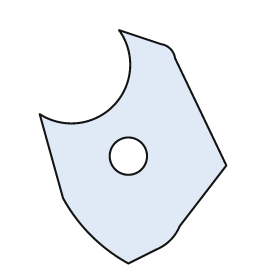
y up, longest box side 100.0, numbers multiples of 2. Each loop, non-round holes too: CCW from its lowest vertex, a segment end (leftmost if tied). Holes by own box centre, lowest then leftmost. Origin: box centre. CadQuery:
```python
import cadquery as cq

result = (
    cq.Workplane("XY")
    .moveTo(-2.0, -50.0)
    .lineTo(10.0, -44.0)
    .threePointArc((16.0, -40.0), (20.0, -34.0))
    .lineTo(40.0, -8.0)
    .lineTo(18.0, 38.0)
    .threePointArc((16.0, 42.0), (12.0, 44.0))
    .lineTo(-6.0, 50.0)
    .threePointArc((-8.0, 18.0), (-40.0, 14.0))
    .lineTo(-30.0, -22.0)
    .threePointArc((-18.0, -38.0), (-2.0, -50.0))
    .close()
    .moveTo(-2.0, -4.0)
    .circle(8.0)
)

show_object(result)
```